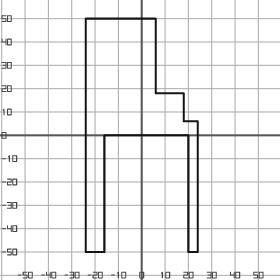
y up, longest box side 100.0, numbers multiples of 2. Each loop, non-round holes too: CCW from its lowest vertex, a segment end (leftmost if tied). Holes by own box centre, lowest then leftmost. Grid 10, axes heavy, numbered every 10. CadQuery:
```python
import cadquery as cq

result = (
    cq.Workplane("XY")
    .moveTo(-24.0, -50.0)
    .lineTo(-16.0, -50.0)
    .lineTo(-16.0, 0.0)
    .lineTo(20.0, 0.0)
    .lineTo(20.0, -50.0)
    .lineTo(24.0, -50.0)
    .lineTo(24.0, 6.0)
    .lineTo(18.0, 6.0)
    .lineTo(18.0, 18.0)
    .lineTo(6.0, 18.0)
    .lineTo(6.0, 50.0)
    .lineTo(-24.0, 50.0)
    .close()
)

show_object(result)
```